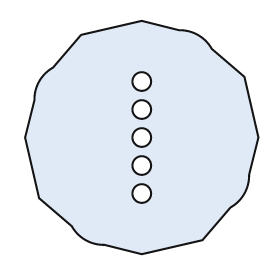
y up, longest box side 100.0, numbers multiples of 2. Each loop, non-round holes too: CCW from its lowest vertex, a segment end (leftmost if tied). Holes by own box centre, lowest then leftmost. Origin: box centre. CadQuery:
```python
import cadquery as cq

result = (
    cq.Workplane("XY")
    .moveTo(0.0, -50.0)
    .lineTo(26.0, -44.0)
    .lineTo(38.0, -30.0)
    .threePointArc((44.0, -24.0), (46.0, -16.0))
    .lineTo(50.0, 0.0)
    .lineTo(44.0, 26.0)
    .lineTo(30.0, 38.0)
    .threePointArc((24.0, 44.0), (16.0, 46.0))
    .lineTo(0.0, 50.0)
    .lineTo(-26.0, 44.0)
    .lineTo(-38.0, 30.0)
    .threePointArc((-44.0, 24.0), (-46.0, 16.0))
    .lineTo(-50.0, 0.0)
    .lineTo(-44.0, -26.0)
    .lineTo(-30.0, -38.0)
    .threePointArc((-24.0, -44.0), (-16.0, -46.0))
    .close()
    .moveTo(0.0, -24.0)
    .circle(4.0)
    .moveTo(0.0, -12.0)
    .circle(4.0)
    .moveTo(0.0, 0.0)
    .circle(4.0)
    .moveTo(0.0, 12.0)
    .circle(4.0)
    .moveTo(0.0, 24.0)
    .circle(4.0)
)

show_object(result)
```